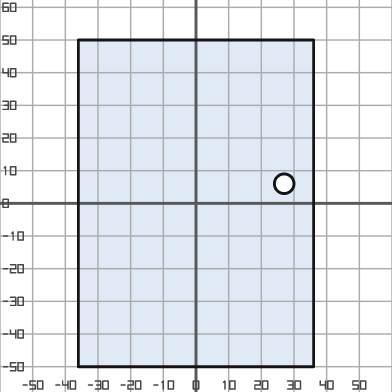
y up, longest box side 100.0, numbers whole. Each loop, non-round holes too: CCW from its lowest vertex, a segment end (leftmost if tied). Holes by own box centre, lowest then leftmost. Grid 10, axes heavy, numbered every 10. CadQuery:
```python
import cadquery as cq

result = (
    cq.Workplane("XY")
    .moveTo(-36.0, -50.0)
    .lineTo(36.0, -50.0)
    .lineTo(36.0, 50.0)
    .lineTo(-36.0, 50.0)
    .close()
    .moveTo(27.0, 6.0)
    .circle(3.0)
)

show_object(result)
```